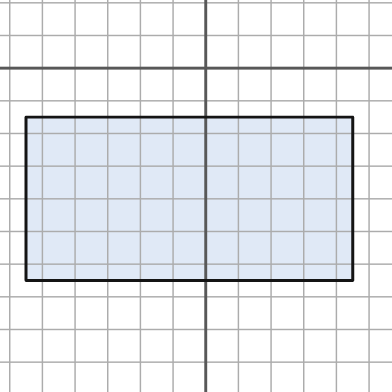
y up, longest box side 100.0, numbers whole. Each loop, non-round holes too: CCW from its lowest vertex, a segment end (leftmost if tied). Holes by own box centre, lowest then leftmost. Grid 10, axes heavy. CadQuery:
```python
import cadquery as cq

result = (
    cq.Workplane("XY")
    .moveTo(-55.0, -65.0)
    .lineTo(45.0, -65.0)
    .lineTo(45.0, -15.0)
    .lineTo(-55.0, -15.0)
    .close()
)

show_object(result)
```